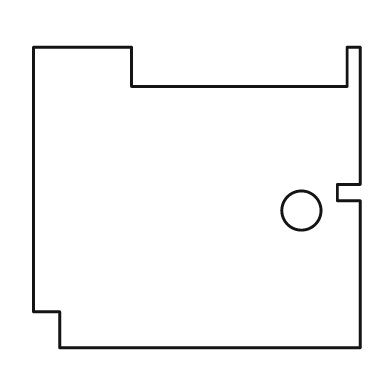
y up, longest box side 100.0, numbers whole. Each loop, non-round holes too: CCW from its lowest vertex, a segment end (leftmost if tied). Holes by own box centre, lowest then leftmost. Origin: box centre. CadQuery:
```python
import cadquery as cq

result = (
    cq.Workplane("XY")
    .moveTo(-42.0, -46.0)
    .lineTo(50.0, -46.0)
    .lineTo(50.0, -1.0)
    .lineTo(43.0, -1.0)
    .lineTo(43.0, 4.0)
    .lineTo(50.0, 4.0)
    .lineTo(50.0, 46.0)
    .lineTo(46.0, 46.0)
    .lineTo(46.0, 34.0)
    .lineTo(-20.0, 34.0)
    .lineTo(-20.0, 46.0)
    .lineTo(-50.0, 46.0)
    .lineTo(-50.0, -35.0)
    .lineTo(-42.0, -35.0)
    .close()
    .moveTo(32.0, -4.0)
    .circle(6.0)
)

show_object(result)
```